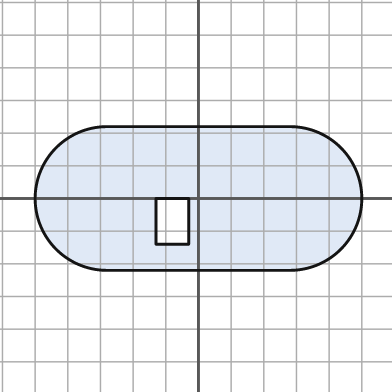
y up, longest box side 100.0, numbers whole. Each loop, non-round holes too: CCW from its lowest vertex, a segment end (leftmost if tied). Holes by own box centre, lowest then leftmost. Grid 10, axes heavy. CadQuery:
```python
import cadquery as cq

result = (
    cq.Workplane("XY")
    .moveTo(-28.0, -22.0)
    .lineTo(28.0, -22.0)
    .threePointArc((50.0, 0.0), (28.0, 22.0))
    .lineTo(-28.0, 22.0)
    .threePointArc((-50.0, 0.0), (-28.0, -22.0))
    .close()
    .moveTo(-13.0, -14.0)
    .lineTo(-3.0, -14.0)
    .lineTo(-3.0, 0.0)
    .lineTo(-13.0, 0.0)
    .close()
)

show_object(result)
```